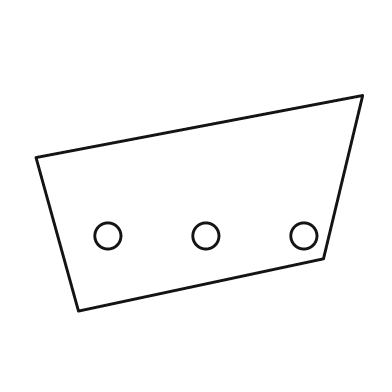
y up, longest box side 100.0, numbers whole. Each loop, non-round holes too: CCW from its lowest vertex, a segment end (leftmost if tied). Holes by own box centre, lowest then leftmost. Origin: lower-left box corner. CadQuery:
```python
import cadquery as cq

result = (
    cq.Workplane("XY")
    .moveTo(13.0, 0.0)
    .lineTo(88.0, 16.0)
    .lineTo(100.0, 66.0)
    .lineTo(0.0, 47.0)
    .close()
    .moveTo(22.0, 23.0)
    .circle(4.0)
    .moveTo(52.0, 23.0)
    .circle(4.0)
    .moveTo(82.0, 23.0)
    .circle(4.0)
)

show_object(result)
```